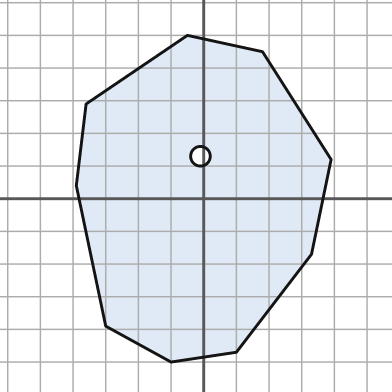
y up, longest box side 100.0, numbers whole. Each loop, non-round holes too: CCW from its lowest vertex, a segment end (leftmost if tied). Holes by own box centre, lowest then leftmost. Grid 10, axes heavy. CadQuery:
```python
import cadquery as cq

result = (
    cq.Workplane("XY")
    .moveTo(-10.0, -50.0)
    .lineTo(10.0, -47.0)
    .lineTo(33.0, -17.0)
    .lineTo(39.0, 12.0)
    .lineTo(18.0, 45.0)
    .lineTo(-5.0, 50.0)
    .lineTo(-36.0, 29.0)
    .lineTo(-39.0, 4.0)
    .lineTo(-30.0, -39.0)
    .close()
    .moveTo(-1.0, 13.0)
    .circle(3.0)
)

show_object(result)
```